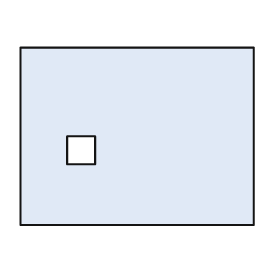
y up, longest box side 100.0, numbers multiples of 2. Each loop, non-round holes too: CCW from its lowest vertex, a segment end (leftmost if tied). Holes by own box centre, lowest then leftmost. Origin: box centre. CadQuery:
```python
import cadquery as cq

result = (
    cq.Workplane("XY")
    .moveTo(-50.0, -38.0)
    .lineTo(50.0, -38.0)
    .lineTo(50.0, 38.0)
    .lineTo(-50.0, 38.0)
    .close()
    .moveTo(-30.0, -12.0)
    .lineTo(-18.0, -12.0)
    .lineTo(-18.0, 0.0)
    .lineTo(-30.0, 0.0)
    .close()
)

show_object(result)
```